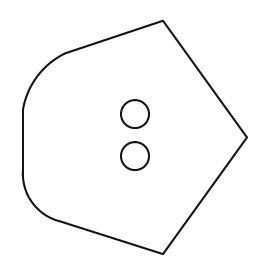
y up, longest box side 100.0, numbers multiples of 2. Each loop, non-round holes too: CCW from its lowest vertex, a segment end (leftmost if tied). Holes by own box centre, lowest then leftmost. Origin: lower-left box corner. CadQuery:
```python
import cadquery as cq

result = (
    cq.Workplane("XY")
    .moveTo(60.0, 0.0)
    .lineTo(96.0, 50.0)
    .lineTo(60.0, 100.0)
    .lineTo(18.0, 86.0)
    .threePointArc((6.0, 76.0), (0.0, 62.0))
    .lineTo(0.0, 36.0)
    .threePointArc((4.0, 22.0), (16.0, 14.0))
    .close()
    .moveTo(48.0, 42.0)
    .circle(6.0)
    .moveTo(48.0, 60.0)
    .circle(6.0)
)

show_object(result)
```